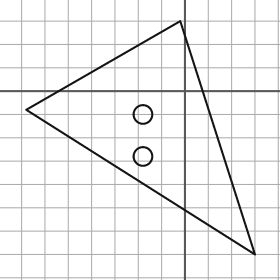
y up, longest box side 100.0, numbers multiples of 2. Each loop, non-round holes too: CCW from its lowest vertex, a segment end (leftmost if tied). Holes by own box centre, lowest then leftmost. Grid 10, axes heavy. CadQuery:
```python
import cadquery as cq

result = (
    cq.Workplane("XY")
    .moveTo(30.0, -70.0)
    .lineTo(-2.0, 30.0)
    .lineTo(-68.0, -8.0)
    .close()
    .moveTo(-18.0, -28.0)
    .circle(4.0)
    .moveTo(-18.0, -10.0)
    .circle(4.0)
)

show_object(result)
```